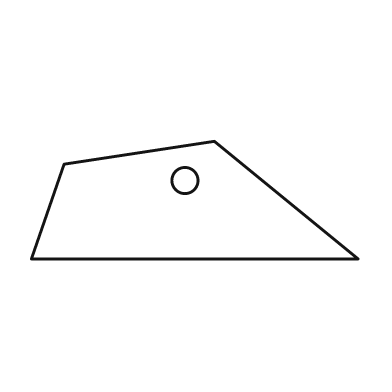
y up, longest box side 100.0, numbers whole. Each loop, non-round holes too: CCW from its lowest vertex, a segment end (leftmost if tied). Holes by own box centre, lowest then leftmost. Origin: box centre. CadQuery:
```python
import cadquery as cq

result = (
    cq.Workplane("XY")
    .moveTo(-50.0, -18.0)
    .lineTo(50.0, -18.0)
    .lineTo(6.0, 18.0)
    .lineTo(-40.0, 11.0)
    .close()
    .moveTo(-3.0, 6.0)
    .circle(4.0)
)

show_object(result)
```